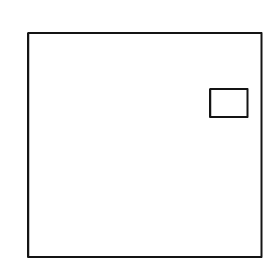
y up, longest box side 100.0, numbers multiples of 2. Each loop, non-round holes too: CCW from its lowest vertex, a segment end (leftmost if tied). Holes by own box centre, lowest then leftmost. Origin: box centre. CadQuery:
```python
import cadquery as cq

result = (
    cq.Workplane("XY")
    .moveTo(-50.0, -48.0)
    .lineTo(50.0, -48.0)
    .lineTo(50.0, 48.0)
    .lineTo(-50.0, 48.0)
    .close()
    .moveTo(28.0, 12.0)
    .lineTo(44.0, 12.0)
    .lineTo(44.0, 24.0)
    .lineTo(28.0, 24.0)
    .close()
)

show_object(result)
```